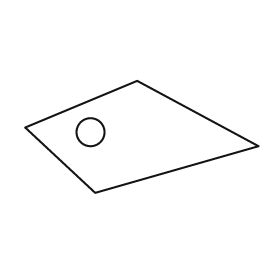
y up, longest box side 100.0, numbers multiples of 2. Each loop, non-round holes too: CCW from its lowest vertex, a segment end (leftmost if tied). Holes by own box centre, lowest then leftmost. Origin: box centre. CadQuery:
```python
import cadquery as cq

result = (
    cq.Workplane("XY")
    .moveTo(-20.0, -24.0)
    .lineTo(50.0, -4.0)
    .lineTo(-2.0, 24.0)
    .lineTo(-50.0, 4.0)
    .close()
    .moveTo(-22.0, 2.0)
    .circle(6.0)
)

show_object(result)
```